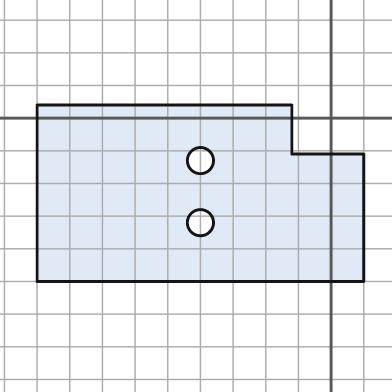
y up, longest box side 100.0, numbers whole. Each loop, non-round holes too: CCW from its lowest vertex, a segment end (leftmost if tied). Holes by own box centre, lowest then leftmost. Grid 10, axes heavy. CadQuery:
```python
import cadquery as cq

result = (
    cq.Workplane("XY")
    .moveTo(-90.0, -50.0)
    .lineTo(10.0, -50.0)
    .lineTo(10.0, -11.0)
    .lineTo(-12.0, -11.0)
    .lineTo(-12.0, 4.0)
    .lineTo(-90.0, 4.0)
    .close()
    .moveTo(-40.0, -32.0)
    .circle(4.0)
    .moveTo(-40.0, -13.0)
    .circle(4.0)
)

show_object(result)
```